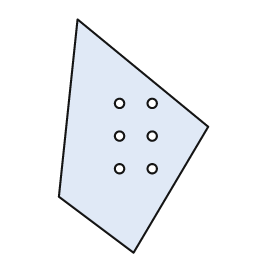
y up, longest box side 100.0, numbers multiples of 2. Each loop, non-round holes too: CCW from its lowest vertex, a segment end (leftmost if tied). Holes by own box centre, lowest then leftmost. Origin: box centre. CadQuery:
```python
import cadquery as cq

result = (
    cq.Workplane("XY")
    .moveTo(0.0, -50.0)
    .lineTo(32.0, 4.0)
    .lineTo(-24.0, 50.0)
    .lineTo(-32.0, -26.0)
    .close()
    .moveTo(-6.0, -14.0)
    .circle(2.0)
    .moveTo(8.0, -14.0)
    .circle(2.0)
    .moveTo(-6.0, 0.0)
    .circle(2.0)
    .moveTo(8.0, 0.0)
    .circle(2.0)
    .moveTo(-6.0, 14.0)
    .circle(2.0)
    .moveTo(8.0, 14.0)
    .circle(2.0)
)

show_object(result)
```